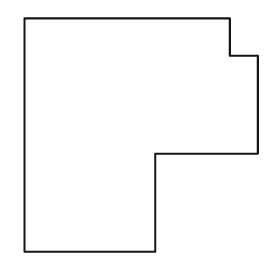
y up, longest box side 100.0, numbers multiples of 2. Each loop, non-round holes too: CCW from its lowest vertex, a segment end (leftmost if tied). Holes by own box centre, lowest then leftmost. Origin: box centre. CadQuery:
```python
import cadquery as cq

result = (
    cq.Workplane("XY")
    .moveTo(-50.0, -50.0)
    .lineTo(6.0, -50.0)
    .lineTo(6.0, -8.0)
    .lineTo(50.0, -8.0)
    .lineTo(50.0, 34.0)
    .lineTo(38.0, 34.0)
    .lineTo(38.0, 50.0)
    .lineTo(-50.0, 50.0)
    .close()
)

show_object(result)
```